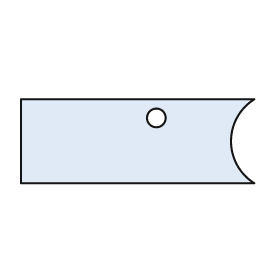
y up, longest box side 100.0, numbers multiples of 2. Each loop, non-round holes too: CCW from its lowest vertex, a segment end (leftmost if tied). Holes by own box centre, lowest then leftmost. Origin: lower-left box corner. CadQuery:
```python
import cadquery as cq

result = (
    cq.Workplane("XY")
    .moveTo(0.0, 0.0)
    .lineTo(100.0, 0.0)
    .threePointArc((90.0, 18.0), (100.0, 36.0))
    .lineTo(0.0, 36.0)
    .close()
    .moveTo(58.0, 28.0)
    .circle(4.0)
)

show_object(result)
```